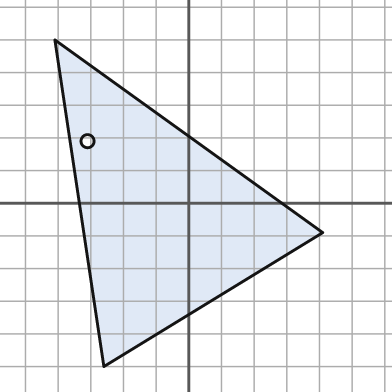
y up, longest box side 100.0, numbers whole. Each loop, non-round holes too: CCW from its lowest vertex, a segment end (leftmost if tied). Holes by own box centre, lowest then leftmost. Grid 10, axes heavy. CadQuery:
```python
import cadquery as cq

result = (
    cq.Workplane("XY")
    .moveTo(-26.0, -50.0)
    .lineTo(41.0, -9.0)
    .lineTo(-41.0, 50.0)
    .close()
    .moveTo(-31.0, 19.0)
    .circle(2.0)
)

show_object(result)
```